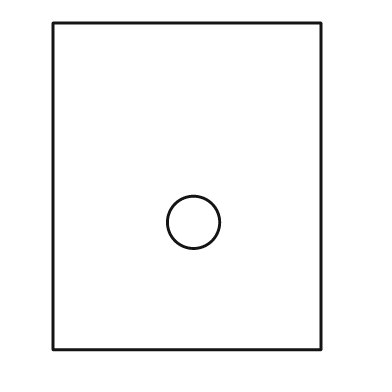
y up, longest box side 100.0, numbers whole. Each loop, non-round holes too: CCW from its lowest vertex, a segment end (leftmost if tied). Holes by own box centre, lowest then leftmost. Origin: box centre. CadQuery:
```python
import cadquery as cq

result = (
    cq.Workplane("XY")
    .moveTo(-41.0, -50.0)
    .lineTo(41.0, -50.0)
    .lineTo(41.0, 50.0)
    .lineTo(-41.0, 50.0)
    .close()
    .moveTo(2.0, -11.0)
    .circle(8.0)
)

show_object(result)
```